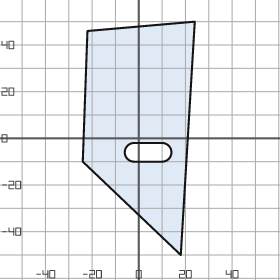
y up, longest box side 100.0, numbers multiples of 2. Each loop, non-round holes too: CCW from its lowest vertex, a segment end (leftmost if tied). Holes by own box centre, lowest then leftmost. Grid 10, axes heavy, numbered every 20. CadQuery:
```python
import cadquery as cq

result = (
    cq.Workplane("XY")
    .moveTo(18.0, -50.0)
    .lineTo(24.0, 50.0)
    .lineTo(-22.0, 46.0)
    .lineTo(-24.0, -10.0)
    .close()
    .moveTo(-2.0, -10.0)
    .lineTo(10.0, -10.0)
    .threePointArc((14.0, -6.0), (10.0, -2.0))
    .lineTo(-2.0, -2.0)
    .threePointArc((-6.0, -6.0), (-2.0, -10.0))
    .close()
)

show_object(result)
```